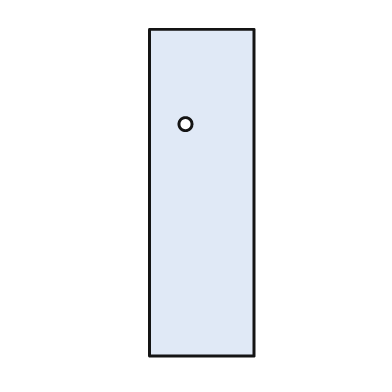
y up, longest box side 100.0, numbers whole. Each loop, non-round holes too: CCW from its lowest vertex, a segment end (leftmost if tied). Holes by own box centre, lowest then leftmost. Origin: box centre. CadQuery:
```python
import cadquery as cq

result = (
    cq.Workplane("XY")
    .moveTo(-16.0, -50.0)
    .lineTo(16.0, -50.0)
    .lineTo(16.0, 50.0)
    .lineTo(-16.0, 50.0)
    .close()
    .moveTo(-5.0, 21.0)
    .circle(2.0)
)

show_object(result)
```